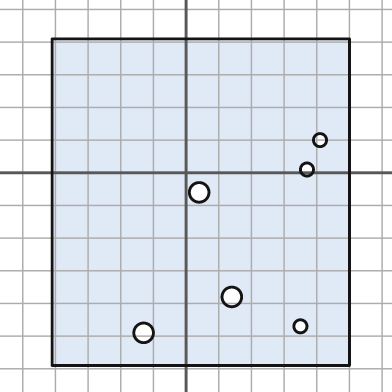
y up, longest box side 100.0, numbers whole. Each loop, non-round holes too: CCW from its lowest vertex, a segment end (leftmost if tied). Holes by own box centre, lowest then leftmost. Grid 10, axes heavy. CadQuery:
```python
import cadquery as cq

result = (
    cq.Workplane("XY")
    .moveTo(-41.0, -59.0)
    .lineTo(50.0, -59.0)
    .lineTo(50.0, 41.0)
    .lineTo(-41.0, 41.0)
    .close()
    .moveTo(-13.0, -49.0)
    .circle(3.0)
    .moveTo(35.0, -47.0)
    .circle(2.0)
    .moveTo(14.0, -38.0)
    .circle(3.0)
    .moveTo(4.0, -6.0)
    .circle(3.0)
    .moveTo(37.0, 1.0)
    .circle(2.0)
    .moveTo(41.0, 10.0)
    .circle(2.0)
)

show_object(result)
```